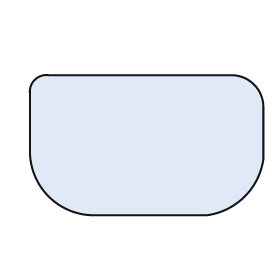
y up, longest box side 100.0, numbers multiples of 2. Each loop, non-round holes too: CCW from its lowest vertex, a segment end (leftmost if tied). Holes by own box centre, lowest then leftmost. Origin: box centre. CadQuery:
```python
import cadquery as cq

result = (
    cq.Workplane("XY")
    .moveTo(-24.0, -30.0)
    .lineTo(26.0, -30.0)
    .threePointArc((42.0, -22.0), (50.0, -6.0))
    .lineTo(50.0, 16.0)
    .threePointArc((46.0, 26.0), (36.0, 30.0))
    .lineTo(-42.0, 30.0)
    .threePointArc((-48.0, 28.0), (-50.0, 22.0))
    .lineTo(-50.0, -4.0)
    .threePointArc((-42.0, -22.0), (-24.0, -30.0))
    .close()
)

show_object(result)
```